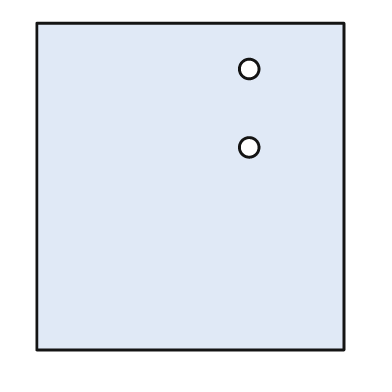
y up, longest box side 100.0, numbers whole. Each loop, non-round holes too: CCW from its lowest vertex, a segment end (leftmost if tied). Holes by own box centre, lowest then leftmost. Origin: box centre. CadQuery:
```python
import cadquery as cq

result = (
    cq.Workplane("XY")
    .moveTo(-47.0, -50.0)
    .lineTo(47.0, -50.0)
    .lineTo(47.0, 50.0)
    .lineTo(-47.0, 50.0)
    .close()
    .moveTo(18.0, 12.0)
    .circle(3.0)
    .moveTo(18.0, 36.0)
    .circle(3.0)
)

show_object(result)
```